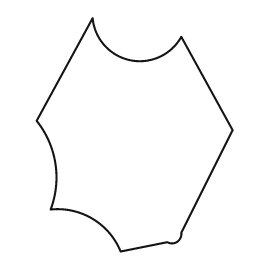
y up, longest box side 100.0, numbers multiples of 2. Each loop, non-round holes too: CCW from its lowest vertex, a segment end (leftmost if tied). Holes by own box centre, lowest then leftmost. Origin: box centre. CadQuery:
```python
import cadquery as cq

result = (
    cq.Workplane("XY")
    .moveTo(-6.0, -50.0)
    .lineTo(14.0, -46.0)
    .threePointArc((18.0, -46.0), (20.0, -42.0))
    .lineTo(42.0, 2.0)
    .lineTo(20.0, 42.0)
    .threePointArc((-2.0, 32.0), (-18.0, 50.0))
    .lineTo(-42.0, 6.0)
    .threePointArc((-34.0, -12.0), (-36.0, -32.0))
    .threePointArc((-18.0, -36.0), (-6.0, -50.0))
    .close()
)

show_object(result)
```